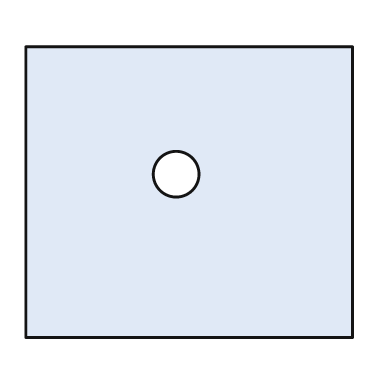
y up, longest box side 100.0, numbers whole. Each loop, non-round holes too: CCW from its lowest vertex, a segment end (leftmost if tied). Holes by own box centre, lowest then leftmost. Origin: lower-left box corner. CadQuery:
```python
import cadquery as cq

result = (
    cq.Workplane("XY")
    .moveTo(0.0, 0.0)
    .lineTo(100.0, 0.0)
    .lineTo(100.0, 89.0)
    .lineTo(0.0, 89.0)
    .close()
    .moveTo(46.0, 50.0)
    .circle(7.0)
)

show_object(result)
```